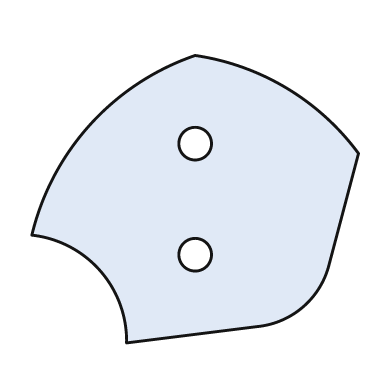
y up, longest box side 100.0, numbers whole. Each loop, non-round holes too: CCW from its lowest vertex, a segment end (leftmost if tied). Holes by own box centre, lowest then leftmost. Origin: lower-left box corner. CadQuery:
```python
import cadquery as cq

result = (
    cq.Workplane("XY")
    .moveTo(29.0, 0.0)
    .lineTo(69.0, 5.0)
    .threePointArc((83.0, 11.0), (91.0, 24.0))
    .lineTo(100.0, 58.0)
    .threePointArc((78.0, 78.0), (50.0, 88.0))
    .threePointArc((18.0, 67.0), (0.0, 33.0))
    .threePointArc((21.0, 22.0), (29.0, 0.0))
    .close()
    .moveTo(50.0, 27.0)
    .circle(5.0)
    .moveTo(50.0, 61.0)
    .circle(5.0)
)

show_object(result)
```